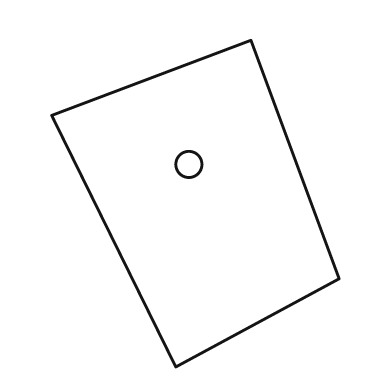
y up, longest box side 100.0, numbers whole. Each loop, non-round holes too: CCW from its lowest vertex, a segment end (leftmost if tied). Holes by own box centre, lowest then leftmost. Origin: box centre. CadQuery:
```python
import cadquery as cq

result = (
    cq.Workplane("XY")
    .moveTo(-6.0, -50.0)
    .lineTo(44.0, -23.0)
    .lineTo(17.0, 50.0)
    .lineTo(-44.0, 27.0)
    .close()
    .moveTo(-2.0, 12.0)
    .circle(4.0)
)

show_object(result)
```